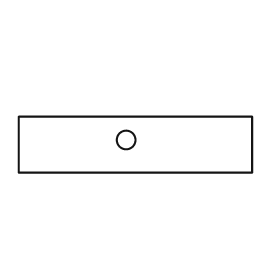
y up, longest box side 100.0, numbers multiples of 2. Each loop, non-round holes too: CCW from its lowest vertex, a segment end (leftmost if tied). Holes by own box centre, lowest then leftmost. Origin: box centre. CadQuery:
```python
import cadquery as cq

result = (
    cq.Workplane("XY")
    .moveTo(-50.0, -12.0)
    .lineTo(50.0, -12.0)
    .lineTo(50.0, 12.0)
    .lineTo(-50.0, 12.0)
    .close()
    .moveTo(-4.0, 2.0)
    .circle(4.0)
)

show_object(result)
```